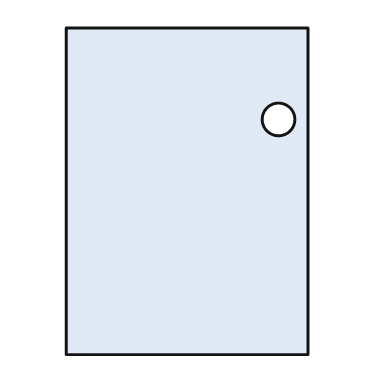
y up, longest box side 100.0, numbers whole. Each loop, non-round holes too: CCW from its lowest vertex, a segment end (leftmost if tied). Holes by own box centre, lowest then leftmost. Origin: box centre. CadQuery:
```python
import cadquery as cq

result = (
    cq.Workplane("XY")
    .moveTo(-37.0, -50.0)
    .lineTo(37.0, -50.0)
    .lineTo(37.0, 50.0)
    .lineTo(-37.0, 50.0)
    .close()
    .moveTo(28.0, 22.0)
    .circle(5.0)
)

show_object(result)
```